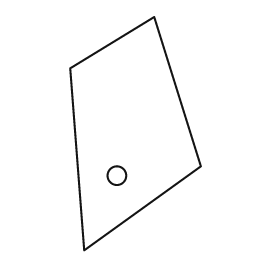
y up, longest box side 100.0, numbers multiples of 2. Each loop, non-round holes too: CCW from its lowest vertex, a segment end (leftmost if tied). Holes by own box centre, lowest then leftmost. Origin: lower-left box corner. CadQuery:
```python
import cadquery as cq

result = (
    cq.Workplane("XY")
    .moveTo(6.0, 0.0)
    .lineTo(56.0, 36.0)
    .lineTo(36.0, 100.0)
    .lineTo(0.0, 78.0)
    .close()
    .moveTo(20.0, 32.0)
    .circle(4.0)
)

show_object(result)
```